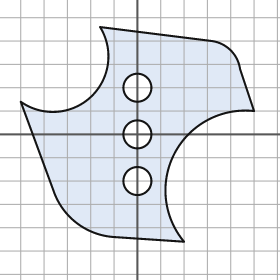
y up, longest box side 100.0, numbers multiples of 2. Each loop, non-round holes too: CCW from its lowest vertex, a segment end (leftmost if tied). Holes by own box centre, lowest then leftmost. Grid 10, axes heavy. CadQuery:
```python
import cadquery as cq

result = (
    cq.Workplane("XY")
    .moveTo(20.0, -46.0)
    .threePointArc((16.0, -8.0), (50.0, 10.0))
    .lineTo(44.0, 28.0)
    .threePointArc((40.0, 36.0), (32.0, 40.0))
    .lineTo(-16.0, 46.0)
    .threePointArc((-20.0, 16.0), (-50.0, 14.0))
    .lineTo(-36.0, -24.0)
    .threePointArc((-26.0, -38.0), (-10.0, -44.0))
    .close()
    .moveTo(0.0, -20.0)
    .circle(6.0)
    .moveTo(0.0, 0.0)
    .circle(6.0)
    .moveTo(0.0, 20.0)
    .circle(6.0)
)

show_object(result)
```